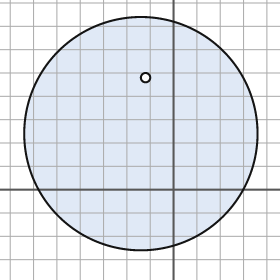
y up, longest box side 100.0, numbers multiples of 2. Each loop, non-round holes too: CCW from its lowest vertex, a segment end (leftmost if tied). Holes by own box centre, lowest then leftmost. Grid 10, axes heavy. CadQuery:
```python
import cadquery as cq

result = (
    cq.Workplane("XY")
    .moveTo(-14.0, 24.0)
    .circle(50.0)
    .moveTo(-12.0, 48.0)
    .circle(2.0)
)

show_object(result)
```